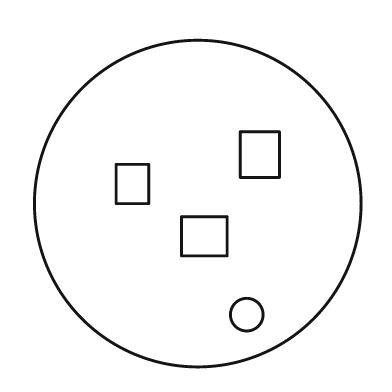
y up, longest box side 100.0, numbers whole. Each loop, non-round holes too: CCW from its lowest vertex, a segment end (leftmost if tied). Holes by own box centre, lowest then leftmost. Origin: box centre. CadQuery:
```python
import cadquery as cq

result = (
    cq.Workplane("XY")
    .moveTo(0.0, 0.0)
    .circle(50.0)
    .moveTo(15.0, -34.0)
    .circle(5.0)
    .moveTo(-5.0, -16.0)
    .lineTo(9.0, -16.0)
    .lineTo(9.0, -4.0)
    .lineTo(-5.0, -4.0)
    .close()
    .moveTo(-25.0, 0.0)
    .lineTo(-15.0, 0.0)
    .lineTo(-15.0, 12.0)
    .lineTo(-25.0, 12.0)
    .close()
    .moveTo(13.0, 8.0)
    .lineTo(25.0, 8.0)
    .lineTo(25.0, 22.0)
    .lineTo(13.0, 22.0)
    .close()
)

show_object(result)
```